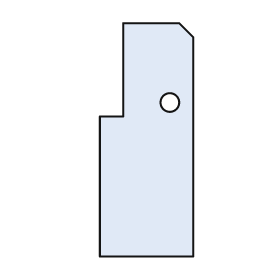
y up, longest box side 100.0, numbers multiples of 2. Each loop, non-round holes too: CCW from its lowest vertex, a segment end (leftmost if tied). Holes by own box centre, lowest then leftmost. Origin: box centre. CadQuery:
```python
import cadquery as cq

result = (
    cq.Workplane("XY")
    .moveTo(-20.0, -50.0)
    .lineTo(20.0, -50.0)
    .lineTo(20.0, 44.0)
    .lineTo(14.0, 50.0)
    .lineTo(-10.0, 50.0)
    .lineTo(-10.0, 10.0)
    .lineTo(-20.0, 10.0)
    .close()
    .moveTo(10.0, 16.0)
    .circle(4.0)
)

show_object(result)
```